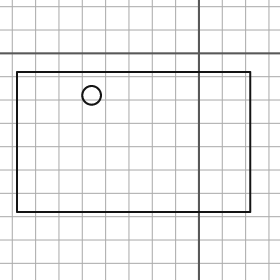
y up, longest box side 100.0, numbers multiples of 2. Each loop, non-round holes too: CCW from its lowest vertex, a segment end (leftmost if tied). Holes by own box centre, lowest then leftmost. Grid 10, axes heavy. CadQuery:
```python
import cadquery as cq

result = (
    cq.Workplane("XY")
    .moveTo(-78.0, -68.0)
    .lineTo(22.0, -68.0)
    .lineTo(22.0, -8.0)
    .lineTo(-78.0, -8.0)
    .close()
    .moveTo(-46.0, -18.0)
    .circle(4.0)
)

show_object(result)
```